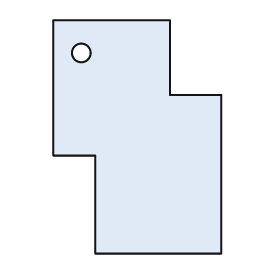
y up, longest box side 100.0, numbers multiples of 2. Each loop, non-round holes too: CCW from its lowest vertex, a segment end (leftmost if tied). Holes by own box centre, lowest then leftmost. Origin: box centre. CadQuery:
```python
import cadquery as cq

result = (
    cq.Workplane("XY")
    .moveTo(-18.0, -50.0)
    .lineTo(36.0, -50.0)
    .lineTo(36.0, 18.0)
    .lineTo(14.0, 18.0)
    .lineTo(14.0, 50.0)
    .lineTo(-36.0, 50.0)
    .lineTo(-36.0, -8.0)
    .lineTo(-18.0, -8.0)
    .close()
    .moveTo(-24.0, 36.0)
    .circle(4.0)
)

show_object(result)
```